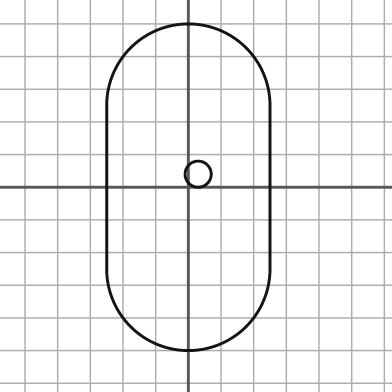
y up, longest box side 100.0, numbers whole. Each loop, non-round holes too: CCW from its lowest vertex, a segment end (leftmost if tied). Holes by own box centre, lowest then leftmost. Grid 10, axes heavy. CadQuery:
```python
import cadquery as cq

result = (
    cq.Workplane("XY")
    .moveTo(-25.0, -25.0)
    .threePointArc((0.0, -50.0), (25.0, -25.0))
    .lineTo(25.0, 25.0)
    .threePointArc((0.0, 50.0), (-25.0, 25.0))
    .close()
    .moveTo(3.0, 4.0)
    .circle(4.0)
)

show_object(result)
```